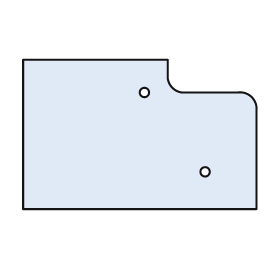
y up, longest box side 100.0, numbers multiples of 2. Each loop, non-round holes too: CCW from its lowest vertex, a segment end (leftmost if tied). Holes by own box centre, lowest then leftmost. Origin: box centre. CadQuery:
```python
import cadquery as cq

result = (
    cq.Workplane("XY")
    .moveTo(-50.0, -32.0)
    .lineTo(50.0, -32.0)
    .lineTo(50.0, 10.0)
    .threePointArc((48.0, 16.0), (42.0, 18.0))
    .lineTo(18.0, 18.0)
    .threePointArc((14.0, 20.0), (12.0, 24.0))
    .lineTo(12.0, 32.0)
    .lineTo(-50.0, 32.0)
    .close()
    .moveTo(28.0, -16.0)
    .circle(2.0)
    .moveTo(2.0, 18.0)
    .circle(2.0)
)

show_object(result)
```